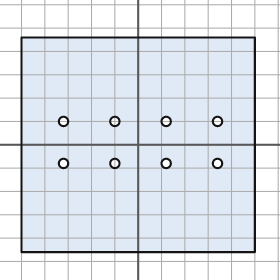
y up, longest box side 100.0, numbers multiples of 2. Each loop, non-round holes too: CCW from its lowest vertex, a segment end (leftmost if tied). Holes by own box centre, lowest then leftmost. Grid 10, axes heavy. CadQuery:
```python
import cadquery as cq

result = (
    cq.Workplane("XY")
    .moveTo(-50.0, -46.0)
    .lineTo(50.0, -46.0)
    .lineTo(50.0, 46.0)
    .lineTo(-50.0, 46.0)
    .close()
    .moveTo(-32.0, -8.0)
    .circle(2.0)
    .moveTo(-10.0, -8.0)
    .circle(2.0)
    .moveTo(12.0, -8.0)
    .circle(2.0)
    .moveTo(34.0, -8.0)
    .circle(2.0)
    .moveTo(-32.0, 10.0)
    .circle(2.0)
    .moveTo(-10.0, 10.0)
    .circle(2.0)
    .moveTo(12.0, 10.0)
    .circle(2.0)
    .moveTo(34.0, 10.0)
    .circle(2.0)
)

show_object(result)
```